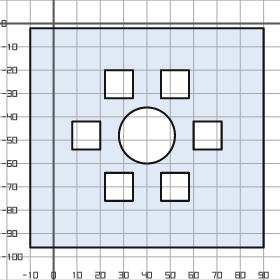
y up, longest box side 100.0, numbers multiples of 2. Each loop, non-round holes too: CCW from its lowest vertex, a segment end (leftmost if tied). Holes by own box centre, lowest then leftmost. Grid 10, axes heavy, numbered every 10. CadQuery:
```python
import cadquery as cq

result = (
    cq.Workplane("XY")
    .moveTo(-10.0, -96.0)
    .lineTo(90.0, -96.0)
    .lineTo(90.0, -2.0)
    .lineTo(-10.0, -2.0)
    .close()
    .moveTo(22.0, -76.0)
    .lineTo(34.0, -76.0)
    .lineTo(34.0, -64.0)
    .lineTo(22.0, -64.0)
    .close()
    .moveTo(46.0, -76.0)
    .lineTo(58.0, -76.0)
    .lineTo(58.0, -64.0)
    .lineTo(46.0, -64.0)
    .close()
    .moveTo(8.0, -54.0)
    .lineTo(20.0, -54.0)
    .lineTo(20.0, -42.0)
    .lineTo(8.0, -42.0)
    .close()
    .moveTo(40.0, -48.0)
    .circle(12.0)
    .moveTo(60.0, -54.0)
    .lineTo(72.0, -54.0)
    .lineTo(72.0, -42.0)
    .lineTo(60.0, -42.0)
    .close()
    .moveTo(22.0, -32.0)
    .lineTo(34.0, -32.0)
    .lineTo(34.0, -20.0)
    .lineTo(22.0, -20.0)
    .close()
    .moveTo(46.0, -32.0)
    .lineTo(58.0, -32.0)
    .lineTo(58.0, -20.0)
    .lineTo(46.0, -20.0)
    .close()
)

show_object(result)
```